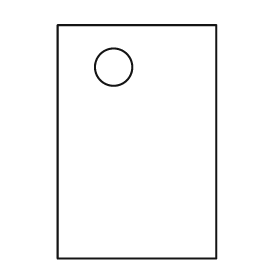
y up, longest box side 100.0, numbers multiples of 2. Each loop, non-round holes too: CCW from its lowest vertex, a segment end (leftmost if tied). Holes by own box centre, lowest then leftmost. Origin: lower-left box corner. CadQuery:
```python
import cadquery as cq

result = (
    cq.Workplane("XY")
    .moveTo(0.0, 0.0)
    .lineTo(68.0, 0.0)
    .lineTo(68.0, 100.0)
    .lineTo(0.0, 100.0)
    .close()
    .moveTo(24.0, 82.0)
    .circle(8.0)
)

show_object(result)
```